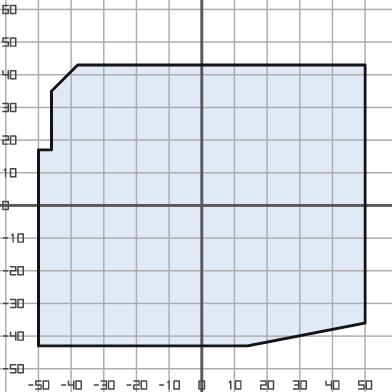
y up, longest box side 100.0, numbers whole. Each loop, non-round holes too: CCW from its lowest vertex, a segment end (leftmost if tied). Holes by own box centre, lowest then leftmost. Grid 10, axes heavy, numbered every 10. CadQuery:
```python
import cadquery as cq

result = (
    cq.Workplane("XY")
    .moveTo(-50.0, -43.0)
    .lineTo(14.0, -43.0)
    .lineTo(50.0, -36.0)
    .lineTo(50.0, 43.0)
    .lineTo(-38.0, 43.0)
    .lineTo(-46.0, 35.0)
    .lineTo(-46.0, 17.0)
    .lineTo(-50.0, 17.0)
    .close()
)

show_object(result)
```